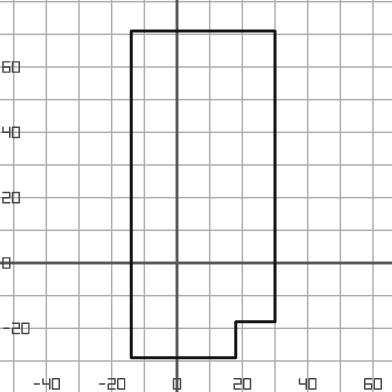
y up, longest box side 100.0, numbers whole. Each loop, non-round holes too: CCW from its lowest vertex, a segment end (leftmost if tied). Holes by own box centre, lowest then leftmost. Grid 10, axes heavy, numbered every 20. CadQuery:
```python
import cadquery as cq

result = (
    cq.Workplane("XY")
    .moveTo(-14.0, -29.0)
    .lineTo(18.0, -29.0)
    .lineTo(18.0, -18.0)
    .lineTo(30.0, -18.0)
    .lineTo(30.0, 71.0)
    .lineTo(-14.0, 71.0)
    .close()
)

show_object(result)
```